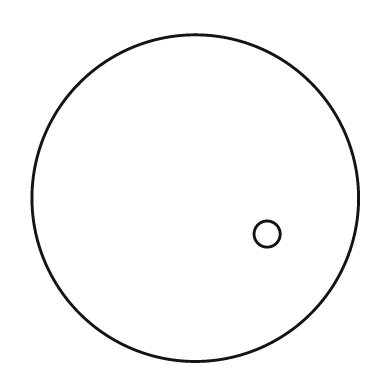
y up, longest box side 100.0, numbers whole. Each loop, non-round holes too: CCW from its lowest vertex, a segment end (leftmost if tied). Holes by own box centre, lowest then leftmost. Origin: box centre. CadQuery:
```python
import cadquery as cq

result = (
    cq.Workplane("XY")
    .moveTo(0.0, 0.0)
    .circle(50.0)
    .moveTo(22.0, -11.0)
    .circle(4.0)
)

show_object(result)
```